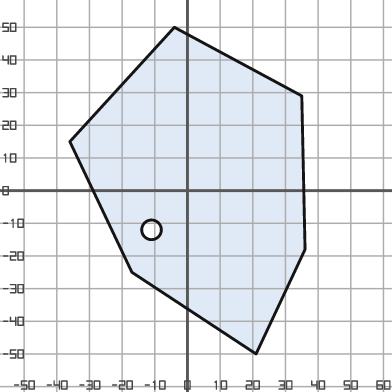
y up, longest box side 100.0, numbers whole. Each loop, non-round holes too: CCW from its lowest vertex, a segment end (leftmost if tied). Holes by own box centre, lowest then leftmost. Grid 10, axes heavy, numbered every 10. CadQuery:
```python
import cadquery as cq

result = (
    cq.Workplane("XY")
    .moveTo(21.0, -50.0)
    .lineTo(36.0, -18.0)
    .lineTo(35.0, 29.0)
    .lineTo(-4.0, 50.0)
    .lineTo(-36.0, 15.0)
    .lineTo(-17.0, -25.0)
    .close()
    .moveTo(-11.0, -12.0)
    .circle(3.0)
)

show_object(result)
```